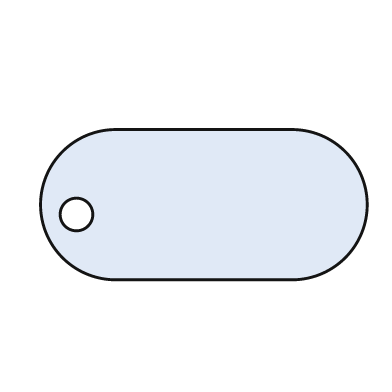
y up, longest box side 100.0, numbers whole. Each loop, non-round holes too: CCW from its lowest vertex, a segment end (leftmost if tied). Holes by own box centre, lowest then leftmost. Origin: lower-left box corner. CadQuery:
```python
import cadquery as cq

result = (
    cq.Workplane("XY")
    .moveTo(23.0, 0.0)
    .lineTo(77.0, 0.0)
    .threePointArc((100.0, 23.0), (77.0, 46.0))
    .lineTo(23.0, 46.0)
    .threePointArc((0.0, 23.0), (23.0, 0.0))
    .close()
    .moveTo(11.0, 20.0)
    .circle(5.0)
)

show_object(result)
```